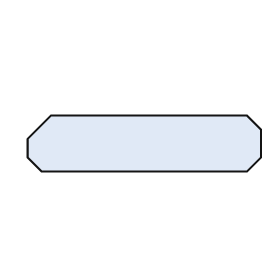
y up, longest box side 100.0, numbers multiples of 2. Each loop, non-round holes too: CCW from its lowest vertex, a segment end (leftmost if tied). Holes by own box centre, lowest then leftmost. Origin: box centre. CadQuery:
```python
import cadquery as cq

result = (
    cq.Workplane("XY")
    .moveTo(-44.0, -12.0)
    .lineTo(44.0, -12.0)
    .lineTo(50.0, -6.0)
    .lineTo(50.0, 6.0)
    .lineTo(44.0, 12.0)
    .lineTo(-40.0, 12.0)
    .lineTo(-50.0, 2.0)
    .lineTo(-50.0, -6.0)
    .close()
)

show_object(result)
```